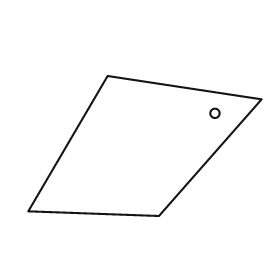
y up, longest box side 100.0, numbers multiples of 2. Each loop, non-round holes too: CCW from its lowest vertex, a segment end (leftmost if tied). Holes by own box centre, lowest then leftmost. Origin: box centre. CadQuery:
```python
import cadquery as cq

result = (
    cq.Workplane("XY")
    .moveTo(6.0, -30.0)
    .lineTo(50.0, 20.0)
    .lineTo(-16.0, 30.0)
    .lineTo(-50.0, -28.0)
    .close()
    .moveTo(30.0, 14.0)
    .circle(2.0)
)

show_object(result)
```